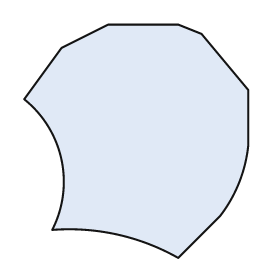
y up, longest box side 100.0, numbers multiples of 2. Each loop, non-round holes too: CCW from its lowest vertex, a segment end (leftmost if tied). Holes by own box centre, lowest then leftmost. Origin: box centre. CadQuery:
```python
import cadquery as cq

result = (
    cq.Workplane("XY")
    .moveTo(18.0, -50.0)
    .lineTo(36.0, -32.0)
    .threePointArc((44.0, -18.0), (48.0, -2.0))
    .lineTo(48.0, 22.0)
    .lineTo(28.0, 46.0)
    .lineTo(18.0, 50.0)
    .lineTo(-12.0, 50.0)
    .lineTo(-32.0, 40.0)
    .lineTo(-48.0, 18.0)
    .threePointArc((-32.0, -8.0), (-36.0, -38.0))
    .threePointArc((-8.0, -40.0), (18.0, -50.0))
    .close()
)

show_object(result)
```